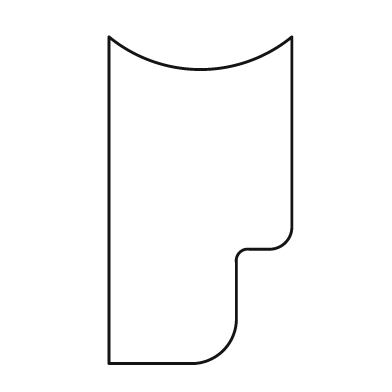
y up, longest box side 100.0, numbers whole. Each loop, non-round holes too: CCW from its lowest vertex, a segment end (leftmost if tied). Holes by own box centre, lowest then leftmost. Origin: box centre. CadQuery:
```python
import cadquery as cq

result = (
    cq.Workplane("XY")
    .moveTo(-28.0, -50.0)
    .lineTo(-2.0, -50.0)
    .threePointArc((7.0, -46.0), (11.0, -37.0))
    .lineTo(11.0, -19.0)
    .threePointArc((12.0, -16.0), (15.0, -15.0))
    .lineTo(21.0, -15.0)
    .threePointArc((26.0, -13.0), (28.0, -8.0))
    .lineTo(28.0, 50.0)
    .threePointArc((0.0, 40.0), (-28.0, 50.0))
    .close()
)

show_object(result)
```